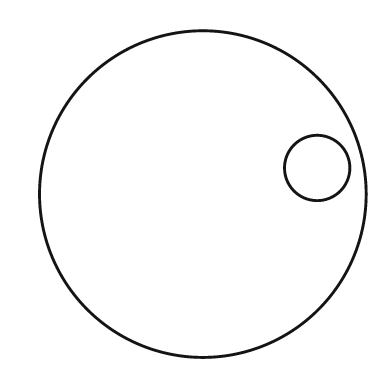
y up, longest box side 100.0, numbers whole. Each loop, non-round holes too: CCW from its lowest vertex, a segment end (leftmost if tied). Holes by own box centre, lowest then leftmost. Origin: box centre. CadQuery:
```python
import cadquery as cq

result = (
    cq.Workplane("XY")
    .moveTo(0.0, 0.0)
    .circle(50.0)
    .moveTo(35.0, 8.0)
    .circle(10.0)
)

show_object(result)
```